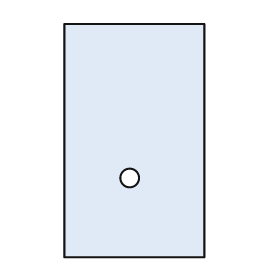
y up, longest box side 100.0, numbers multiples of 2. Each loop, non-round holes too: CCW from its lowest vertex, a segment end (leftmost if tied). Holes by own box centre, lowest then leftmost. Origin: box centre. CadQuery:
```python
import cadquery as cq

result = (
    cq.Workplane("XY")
    .moveTo(-30.0, -50.0)
    .lineTo(30.0, -50.0)
    .lineTo(30.0, 50.0)
    .lineTo(-30.0, 50.0)
    .close()
    .moveTo(-2.0, -16.0)
    .circle(4.0)
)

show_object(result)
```